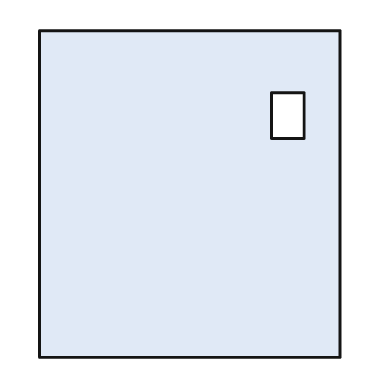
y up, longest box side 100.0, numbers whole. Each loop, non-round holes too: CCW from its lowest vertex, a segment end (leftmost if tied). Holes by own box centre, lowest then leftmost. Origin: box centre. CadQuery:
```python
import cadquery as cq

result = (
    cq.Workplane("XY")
    .moveTo(-46.0, -50.0)
    .lineTo(46.0, -50.0)
    .lineTo(46.0, 50.0)
    .lineTo(-46.0, 50.0)
    .close()
    .moveTo(25.0, 17.0)
    .lineTo(35.0, 17.0)
    .lineTo(35.0, 31.0)
    .lineTo(25.0, 31.0)
    .close()
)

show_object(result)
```